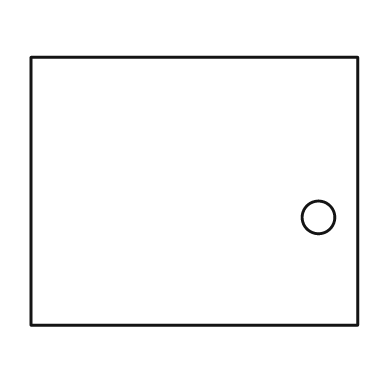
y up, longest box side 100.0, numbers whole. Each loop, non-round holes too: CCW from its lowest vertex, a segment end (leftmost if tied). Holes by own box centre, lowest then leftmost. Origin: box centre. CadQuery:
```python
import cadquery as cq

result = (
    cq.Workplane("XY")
    .moveTo(-50.0, -41.0)
    .lineTo(50.0, -41.0)
    .lineTo(50.0, 41.0)
    .lineTo(-50.0, 41.0)
    .close()
    .moveTo(38.0, -8.0)
    .circle(5.0)
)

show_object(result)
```